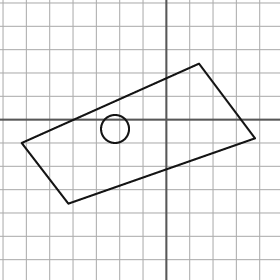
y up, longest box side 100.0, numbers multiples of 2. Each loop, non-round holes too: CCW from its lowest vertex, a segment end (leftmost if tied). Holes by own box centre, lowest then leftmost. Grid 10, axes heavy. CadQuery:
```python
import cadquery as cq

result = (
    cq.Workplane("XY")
    .moveTo(-42.0, -36.0)
    .lineTo(38.0, -8.0)
    .lineTo(14.0, 24.0)
    .lineTo(-62.0, -10.0)
    .close()
    .moveTo(-22.0, -4.0)
    .circle(6.0)
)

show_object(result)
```